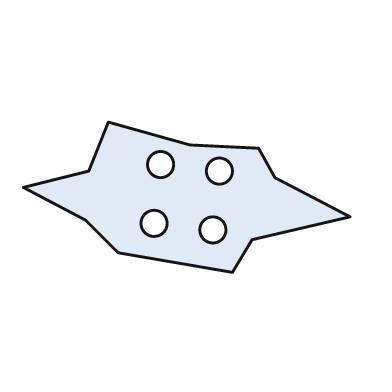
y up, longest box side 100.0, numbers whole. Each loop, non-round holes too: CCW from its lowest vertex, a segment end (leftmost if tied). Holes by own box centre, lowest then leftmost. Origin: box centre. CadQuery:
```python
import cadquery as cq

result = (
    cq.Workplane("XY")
    .moveTo(14.0, -23.0)
    .lineTo(20.0, -13.0)
    .lineTo(50.0, -6.0)
    .lineTo(27.0, 6.0)
    .lineTo(22.0, 15.0)
    .lineTo(1.0, 16.0)
    .lineTo(-24.0, 23.0)
    .lineTo(-30.0, 8.0)
    .lineTo(-50.0, 3.0)
    .lineTo(-31.0, -7.0)
    .lineTo(-21.0, -17.0)
    .close()
    .moveTo(8.0, -10.0)
    .circle(4.0)
    .moveTo(-10.0, -8.0)
    .circle(4.0)
    .moveTo(10.0, 8.0)
    .circle(4.0)
    .moveTo(-8.0, 10.0)
    .circle(4.0)
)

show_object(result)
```